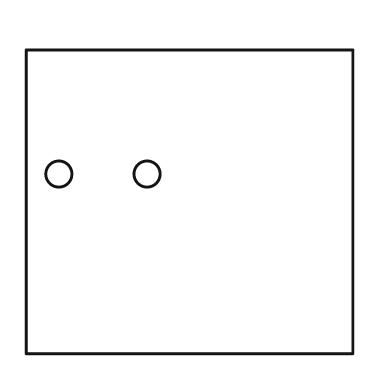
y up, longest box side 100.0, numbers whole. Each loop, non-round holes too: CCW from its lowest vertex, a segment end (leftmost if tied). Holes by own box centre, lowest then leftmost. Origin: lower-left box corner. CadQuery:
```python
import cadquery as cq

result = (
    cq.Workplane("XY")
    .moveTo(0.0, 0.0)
    .lineTo(100.0, 0.0)
    .lineTo(100.0, 93.0)
    .lineTo(0.0, 93.0)
    .close()
    .moveTo(10.0, 55.0)
    .circle(4.0)
    .moveTo(37.0, 55.0)
    .circle(4.0)
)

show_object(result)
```